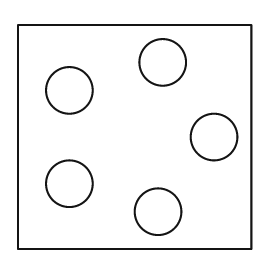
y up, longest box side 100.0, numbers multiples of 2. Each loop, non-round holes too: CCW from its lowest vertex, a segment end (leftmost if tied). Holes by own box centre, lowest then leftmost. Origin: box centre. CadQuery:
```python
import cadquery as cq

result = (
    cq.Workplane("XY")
    .moveTo(-50.0, -48.0)
    .lineTo(50.0, -48.0)
    .lineTo(50.0, 48.0)
    .lineTo(-50.0, 48.0)
    .close()
    .moveTo(10.0, -32.0)
    .circle(10.0)
    .moveTo(-28.0, -20.0)
    .circle(10.0)
    .moveTo(34.0, 0.0)
    .circle(10.0)
    .moveTo(-28.0, 20.0)
    .circle(10.0)
    .moveTo(12.0, 32.0)
    .circle(10.0)
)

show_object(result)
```